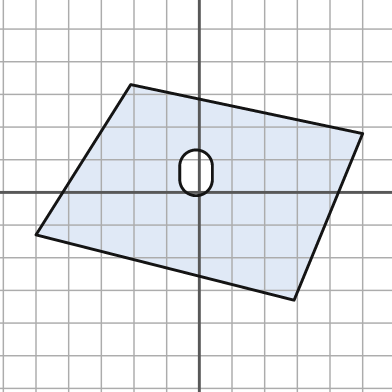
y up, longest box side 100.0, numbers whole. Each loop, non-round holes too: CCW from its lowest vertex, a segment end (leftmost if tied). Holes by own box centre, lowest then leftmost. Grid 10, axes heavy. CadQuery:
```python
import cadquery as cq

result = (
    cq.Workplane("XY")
    .moveTo(29.0, -33.0)
    .lineTo(50.0, 18.0)
    .lineTo(-21.0, 33.0)
    .lineTo(-50.0, -13.0)
    .close()
    .moveTo(-6.0, 4.0)
    .threePointArc((-1.0, -1.0), (4.0, 4.0))
    .lineTo(4.0, 8.0)
    .threePointArc((-1.0, 13.0), (-6.0, 8.0))
    .close()
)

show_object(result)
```